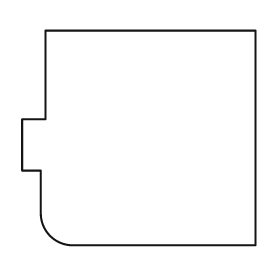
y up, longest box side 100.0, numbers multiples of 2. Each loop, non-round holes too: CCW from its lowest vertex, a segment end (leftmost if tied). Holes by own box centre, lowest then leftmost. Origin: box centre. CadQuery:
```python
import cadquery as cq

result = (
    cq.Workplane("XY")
    .moveTo(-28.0, -46.0)
    .lineTo(50.0, -46.0)
    .lineTo(50.0, 46.0)
    .lineTo(-40.0, 46.0)
    .lineTo(-40.0, 8.0)
    .lineTo(-50.0, 8.0)
    .lineTo(-50.0, -14.0)
    .lineTo(-42.0, -14.0)
    .lineTo(-42.0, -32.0)
    .threePointArc((-38.0, -42.0), (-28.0, -46.0))
    .close()
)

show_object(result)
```